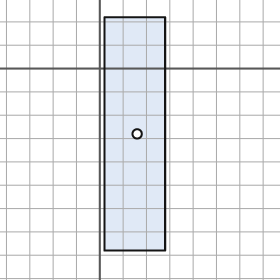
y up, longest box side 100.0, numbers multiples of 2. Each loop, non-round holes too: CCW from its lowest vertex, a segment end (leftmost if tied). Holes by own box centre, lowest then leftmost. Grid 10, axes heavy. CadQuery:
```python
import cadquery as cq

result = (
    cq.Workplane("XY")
    .moveTo(2.0, -78.0)
    .lineTo(28.0, -78.0)
    .lineTo(28.0, 22.0)
    .lineTo(2.0, 22.0)
    .close()
    .moveTo(16.0, -28.0)
    .circle(2.0)
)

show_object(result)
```